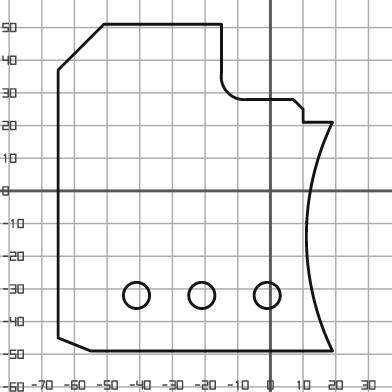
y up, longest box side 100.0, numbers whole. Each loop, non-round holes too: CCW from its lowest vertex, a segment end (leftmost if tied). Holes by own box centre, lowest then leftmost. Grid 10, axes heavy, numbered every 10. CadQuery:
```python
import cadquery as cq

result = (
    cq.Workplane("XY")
    .moveTo(-55.0, -49.0)
    .lineTo(19.0, -49.0)
    .threePointArc((11.0, -14.0), (19.0, 21.0))
    .lineTo(10.0, 21.0)
    .lineTo(10.0, 25.0)
    .lineTo(7.0, 28.0)
    .lineTo(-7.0, 28.0)
    .threePointArc((-13.0, 30.0), (-15.0, 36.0))
    .lineTo(-15.0, 51.0)
    .lineTo(-51.0, 51.0)
    .lineTo(-65.0, 37.0)
    .lineTo(-65.0, -45.0)
    .close()
    .moveTo(-41.0, -32.0)
    .circle(4.0)
    .moveTo(-21.0, -32.0)
    .circle(4.0)
    .moveTo(-1.0, -32.0)
    .circle(4.0)
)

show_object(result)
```